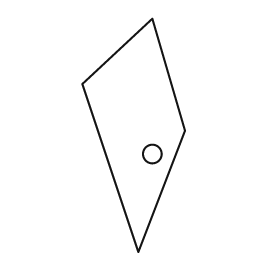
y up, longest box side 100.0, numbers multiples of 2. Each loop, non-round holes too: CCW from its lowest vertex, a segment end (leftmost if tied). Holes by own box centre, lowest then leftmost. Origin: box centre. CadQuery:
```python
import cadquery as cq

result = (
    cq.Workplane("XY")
    .moveTo(2.0, -50.0)
    .lineTo(22.0, 2.0)
    .lineTo(8.0, 50.0)
    .lineTo(-22.0, 22.0)
    .close()
    .moveTo(8.0, -8.0)
    .circle(4.0)
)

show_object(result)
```